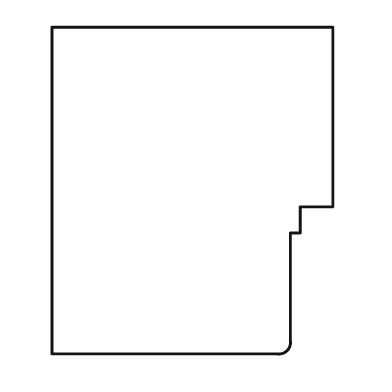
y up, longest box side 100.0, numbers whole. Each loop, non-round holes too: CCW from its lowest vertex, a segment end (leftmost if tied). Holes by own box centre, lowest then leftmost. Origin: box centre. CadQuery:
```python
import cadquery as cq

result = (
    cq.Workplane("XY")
    .moveTo(-43.0, -50.0)
    .lineTo(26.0, -50.0)
    .threePointArc((29.0, -49.0), (30.0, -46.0))
    .lineTo(30.0, -13.0)
    .lineTo(33.0, -13.0)
    .lineTo(33.0, -5.0)
    .lineTo(43.0, -5.0)
    .lineTo(43.0, 50.0)
    .lineTo(-43.0, 50.0)
    .close()
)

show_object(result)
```